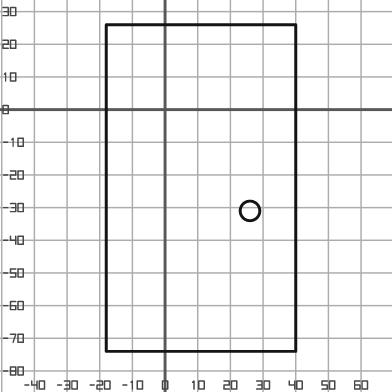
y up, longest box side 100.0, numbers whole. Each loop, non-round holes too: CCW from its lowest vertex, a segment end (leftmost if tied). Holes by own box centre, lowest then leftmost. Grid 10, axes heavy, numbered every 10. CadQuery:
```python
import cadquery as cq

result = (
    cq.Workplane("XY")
    .moveTo(-18.0, -74.0)
    .lineTo(40.0, -74.0)
    .lineTo(40.0, 26.0)
    .lineTo(-18.0, 26.0)
    .close()
    .moveTo(26.0, -31.0)
    .circle(3.0)
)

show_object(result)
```